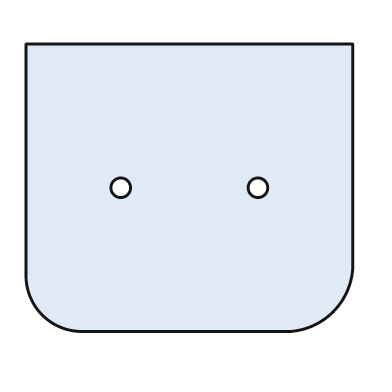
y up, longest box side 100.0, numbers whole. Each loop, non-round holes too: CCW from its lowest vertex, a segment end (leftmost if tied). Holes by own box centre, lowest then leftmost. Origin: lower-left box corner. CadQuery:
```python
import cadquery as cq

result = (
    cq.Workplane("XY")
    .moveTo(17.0, 0.0)
    .lineTo(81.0, 0.0)
    .threePointArc((94.0, 6.0), (100.0, 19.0))
    .lineTo(100.0, 88.0)
    .lineTo(0.0, 88.0)
    .lineTo(0.0, 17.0)
    .threePointArc((5.0, 5.0), (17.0, 0.0))
    .close()
    .moveTo(29.0, 44.0)
    .circle(3.0)
    .moveTo(71.0, 44.0)
    .circle(3.0)
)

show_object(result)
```